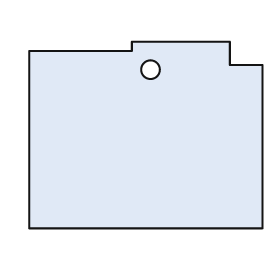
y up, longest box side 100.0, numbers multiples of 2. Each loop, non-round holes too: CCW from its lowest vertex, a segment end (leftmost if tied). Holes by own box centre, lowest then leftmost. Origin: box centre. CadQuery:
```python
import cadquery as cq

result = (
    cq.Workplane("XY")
    .moveTo(-50.0, -40.0)
    .lineTo(50.0, -40.0)
    .lineTo(50.0, 30.0)
    .lineTo(36.0, 30.0)
    .lineTo(36.0, 40.0)
    .lineTo(-6.0, 40.0)
    .lineTo(-6.0, 36.0)
    .lineTo(-50.0, 36.0)
    .close()
    .moveTo(2.0, 28.0)
    .circle(4.0)
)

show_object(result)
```